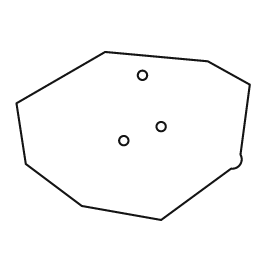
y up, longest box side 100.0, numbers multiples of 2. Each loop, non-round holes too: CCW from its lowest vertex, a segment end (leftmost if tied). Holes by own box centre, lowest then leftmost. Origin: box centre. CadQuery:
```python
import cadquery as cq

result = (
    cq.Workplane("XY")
    .moveTo(12.0, -36.0)
    .lineTo(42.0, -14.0)
    .threePointArc((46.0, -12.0), (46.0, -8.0))
    .lineTo(50.0, 22.0)
    .lineTo(32.0, 32.0)
    .lineTo(-12.0, 36.0)
    .lineTo(-50.0, 14.0)
    .lineTo(-46.0, -12.0)
    .lineTo(-22.0, -30.0)
    .close()
    .moveTo(-4.0, -2.0)
    .circle(2.0)
    .moveTo(12.0, 4.0)
    .circle(2.0)
    .moveTo(4.0, 26.0)
    .circle(2.0)
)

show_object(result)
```